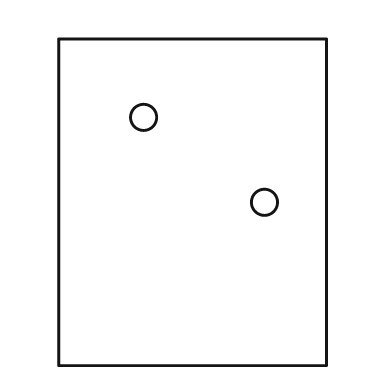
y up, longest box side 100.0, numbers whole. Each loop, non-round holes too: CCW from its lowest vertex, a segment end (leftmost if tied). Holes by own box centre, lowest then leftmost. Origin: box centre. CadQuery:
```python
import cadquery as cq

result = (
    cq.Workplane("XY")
    .moveTo(-41.0, -50.0)
    .lineTo(41.0, -50.0)
    .lineTo(41.0, 50.0)
    .lineTo(-41.0, 50.0)
    .close()
    .moveTo(22.0, 0.0)
    .circle(4.0)
    .moveTo(-15.0, 26.0)
    .circle(4.0)
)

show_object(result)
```